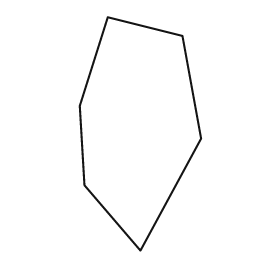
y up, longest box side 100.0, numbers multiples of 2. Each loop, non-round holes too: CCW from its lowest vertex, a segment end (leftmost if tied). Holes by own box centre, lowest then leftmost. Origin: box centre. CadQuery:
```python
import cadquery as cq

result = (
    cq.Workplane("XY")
    .moveTo(0.0, -50.0)
    .lineTo(26.0, -2.0)
    .lineTo(18.0, 42.0)
    .lineTo(-14.0, 50.0)
    .lineTo(-26.0, 12.0)
    .lineTo(-24.0, -22.0)
    .close()
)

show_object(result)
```